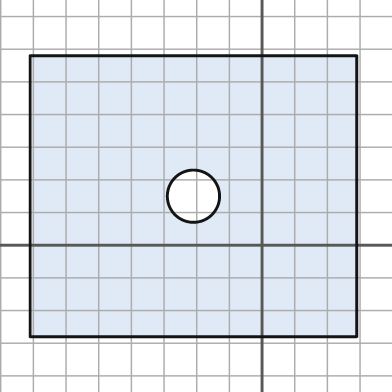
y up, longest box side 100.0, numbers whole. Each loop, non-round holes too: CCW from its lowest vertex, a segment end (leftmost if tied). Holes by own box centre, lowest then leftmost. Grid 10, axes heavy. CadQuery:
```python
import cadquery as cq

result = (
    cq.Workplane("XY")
    .moveTo(-71.0, -28.0)
    .lineTo(29.0, -28.0)
    .lineTo(29.0, 58.0)
    .lineTo(-71.0, 58.0)
    .close()
    .moveTo(-21.0, 15.0)
    .circle(8.0)
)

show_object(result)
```